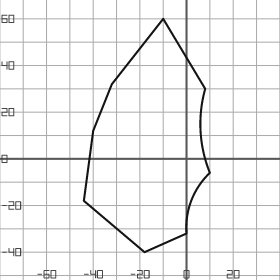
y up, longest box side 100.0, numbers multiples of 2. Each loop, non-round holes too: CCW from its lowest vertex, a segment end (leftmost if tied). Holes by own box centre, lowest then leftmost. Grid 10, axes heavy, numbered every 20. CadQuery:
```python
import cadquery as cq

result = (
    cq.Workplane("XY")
    .moveTo(-18.0, -40.0)
    .lineTo(0.0, -32.0)
    .threePointArc((2.0, -18.0), (10.0, -6.0))
    .threePointArc((6.0, 12.0), (8.0, 30.0))
    .lineTo(-10.0, 60.0)
    .lineTo(-32.0, 32.0)
    .lineTo(-40.0, 12.0)
    .lineTo(-44.0, -18.0)
    .close()
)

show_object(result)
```